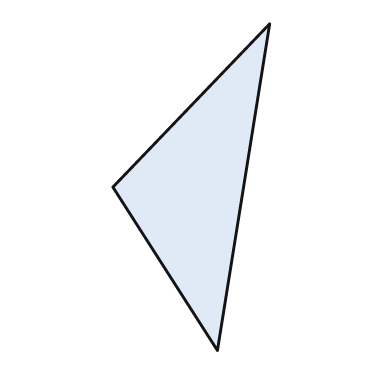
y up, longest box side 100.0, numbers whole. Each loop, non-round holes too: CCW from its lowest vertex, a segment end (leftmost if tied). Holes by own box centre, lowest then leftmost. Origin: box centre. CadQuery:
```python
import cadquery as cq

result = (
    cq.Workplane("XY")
    .moveTo(8.0, -50.0)
    .lineTo(24.0, 50.0)
    .lineTo(-24.0, 0.0)
    .close()
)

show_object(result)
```